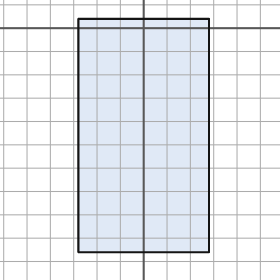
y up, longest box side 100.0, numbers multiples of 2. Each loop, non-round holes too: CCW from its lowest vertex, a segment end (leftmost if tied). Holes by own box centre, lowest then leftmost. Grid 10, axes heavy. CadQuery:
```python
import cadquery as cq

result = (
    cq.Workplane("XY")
    .moveTo(-28.0, -96.0)
    .lineTo(28.0, -96.0)
    .lineTo(28.0, 4.0)
    .lineTo(-28.0, 4.0)
    .close()
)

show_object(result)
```